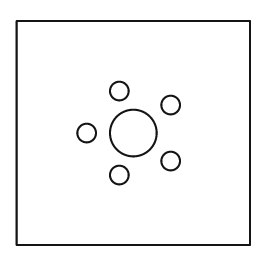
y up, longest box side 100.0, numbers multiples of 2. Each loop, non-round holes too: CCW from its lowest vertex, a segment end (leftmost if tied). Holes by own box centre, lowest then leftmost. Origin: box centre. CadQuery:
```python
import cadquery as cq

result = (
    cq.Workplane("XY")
    .moveTo(-50.0, -48.0)
    .lineTo(50.0, -48.0)
    .lineTo(50.0, 48.0)
    .lineTo(-50.0, 48.0)
    .close()
    .moveTo(-6.0, -18.0)
    .circle(4.0)
    .moveTo(16.0, -12.0)
    .circle(4.0)
    .moveTo(-20.0, 0.0)
    .circle(4.0)
    .moveTo(0.0, 0.0)
    .circle(10.0)
    .moveTo(16.0, 12.0)
    .circle(4.0)
    .moveTo(-6.0, 18.0)
    .circle(4.0)
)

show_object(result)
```